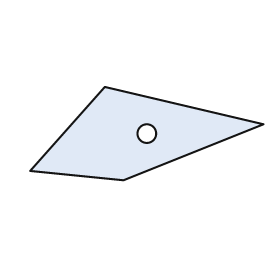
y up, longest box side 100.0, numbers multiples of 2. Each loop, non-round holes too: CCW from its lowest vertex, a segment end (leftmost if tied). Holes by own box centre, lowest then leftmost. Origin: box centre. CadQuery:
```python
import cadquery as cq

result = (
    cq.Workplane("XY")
    .moveTo(-10.0, -20.0)
    .lineTo(50.0, 4.0)
    .lineTo(-18.0, 20.0)
    .lineTo(-50.0, -16.0)
    .close()
    .moveTo(0.0, 0.0)
    .circle(4.0)
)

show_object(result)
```